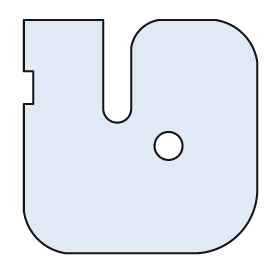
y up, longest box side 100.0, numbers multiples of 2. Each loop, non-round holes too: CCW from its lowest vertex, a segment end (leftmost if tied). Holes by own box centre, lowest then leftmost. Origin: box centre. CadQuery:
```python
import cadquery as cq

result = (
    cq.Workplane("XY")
    .moveTo(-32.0, -50.0)
    .lineTo(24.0, -50.0)
    .threePointArc((42.0, -42.0), (50.0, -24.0))
    .lineTo(50.0, 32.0)
    .threePointArc((44.0, 44.0), (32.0, 50.0))
    .lineTo(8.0, 50.0)
    .threePointArc((0.0, 46.0), (-4.0, 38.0))
    .lineTo(-4.0, 12.0)
    .threePointArc((-10.0, 6.0), (-16.0, 12.0))
    .lineTo(-16.0, 50.0)
    .lineTo(-50.0, 50.0)
    .lineTo(-50.0, 28.0)
    .lineTo(-46.0, 28.0)
    .lineTo(-46.0, 14.0)
    .lineTo(-50.0, 14.0)
    .lineTo(-50.0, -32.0)
    .threePointArc((-44.0, -44.0), (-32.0, -50.0))
    .close()
    .moveTo(12.0, -4.0)
    .circle(6.0)
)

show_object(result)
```